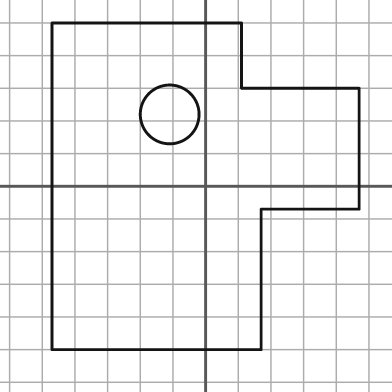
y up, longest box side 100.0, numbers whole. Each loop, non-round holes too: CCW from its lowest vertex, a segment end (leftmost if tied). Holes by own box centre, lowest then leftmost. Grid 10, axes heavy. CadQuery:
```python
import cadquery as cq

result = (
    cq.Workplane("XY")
    .moveTo(-47.0, -50.0)
    .lineTo(17.0, -50.0)
    .lineTo(17.0, -7.0)
    .lineTo(47.0, -7.0)
    .lineTo(47.0, 30.0)
    .lineTo(11.0, 30.0)
    .lineTo(11.0, 50.0)
    .lineTo(-47.0, 50.0)
    .close()
    .moveTo(-11.0, 22.0)
    .circle(9.0)
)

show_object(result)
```